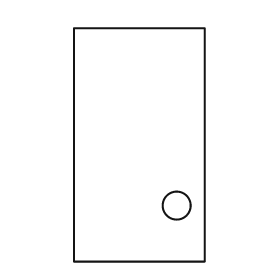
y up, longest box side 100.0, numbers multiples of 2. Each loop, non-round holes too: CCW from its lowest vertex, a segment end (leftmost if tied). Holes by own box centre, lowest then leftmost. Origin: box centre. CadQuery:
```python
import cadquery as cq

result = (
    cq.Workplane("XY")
    .moveTo(-28.0, -50.0)
    .lineTo(28.0, -50.0)
    .lineTo(28.0, 50.0)
    .lineTo(-28.0, 50.0)
    .close()
    .moveTo(16.0, -26.0)
    .circle(6.0)
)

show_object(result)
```